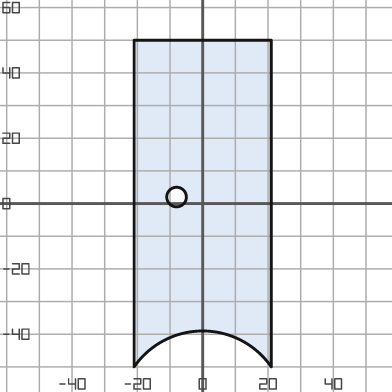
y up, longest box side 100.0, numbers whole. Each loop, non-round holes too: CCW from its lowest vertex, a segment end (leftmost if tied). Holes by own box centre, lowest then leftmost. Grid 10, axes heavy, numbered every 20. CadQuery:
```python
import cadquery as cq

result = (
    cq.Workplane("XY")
    .moveTo(-21.0, -50.0)
    .threePointArc((0.0, -39.0), (21.0, -50.0))
    .lineTo(21.0, 50.0)
    .lineTo(-21.0, 50.0)
    .close()
    .moveTo(-8.0, 2.0)
    .circle(3.0)
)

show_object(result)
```